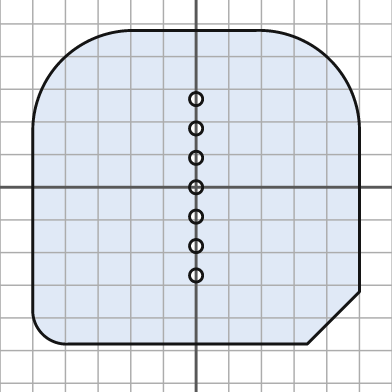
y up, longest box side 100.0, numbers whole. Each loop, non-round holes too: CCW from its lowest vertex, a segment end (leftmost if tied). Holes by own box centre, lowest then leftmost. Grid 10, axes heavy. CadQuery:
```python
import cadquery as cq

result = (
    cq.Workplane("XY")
    .moveTo(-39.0, -48.0)
    .lineTo(34.0, -48.0)
    .lineTo(50.0, -32.0)
    .lineTo(50.0, 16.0)
    .threePointArc((41.0, 39.0), (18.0, 48.0))
    .lineTo(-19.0, 48.0)
    .threePointArc((-41.0, 39.0), (-50.0, 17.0))
    .lineTo(-50.0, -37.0)
    .threePointArc((-47.0, -45.0), (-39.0, -48.0))
    .close()
    .moveTo(0.0, -27.0)
    .circle(2.0)
    .moveTo(0.0, -18.0)
    .circle(2.0)
    .moveTo(0.0, -9.0)
    .circle(2.0)
    .moveTo(0.0, 0.0)
    .circle(2.0)
    .moveTo(0.0, 9.0)
    .circle(2.0)
    .moveTo(0.0, 18.0)
    .circle(2.0)
    .moveTo(0.0, 27.0)
    .circle(2.0)
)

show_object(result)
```